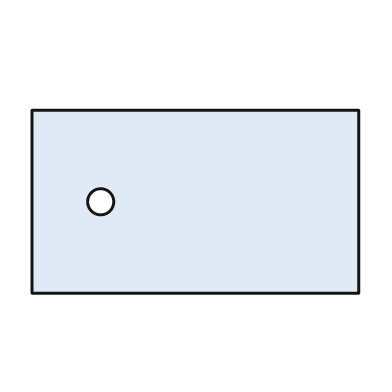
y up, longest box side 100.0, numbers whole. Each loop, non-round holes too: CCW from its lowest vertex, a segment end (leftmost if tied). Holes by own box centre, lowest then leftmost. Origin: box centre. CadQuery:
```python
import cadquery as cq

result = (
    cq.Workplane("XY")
    .moveTo(-50.0, -28.0)
    .lineTo(50.0, -28.0)
    .lineTo(50.0, 28.0)
    .lineTo(-50.0, 28.0)
    .close()
    .moveTo(-29.0, 0.0)
    .circle(4.0)
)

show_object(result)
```